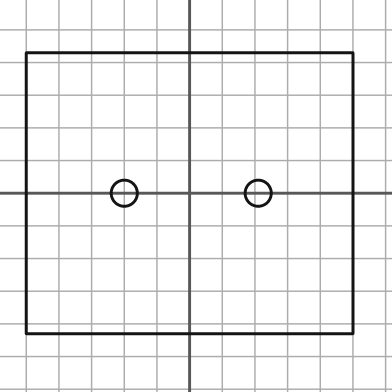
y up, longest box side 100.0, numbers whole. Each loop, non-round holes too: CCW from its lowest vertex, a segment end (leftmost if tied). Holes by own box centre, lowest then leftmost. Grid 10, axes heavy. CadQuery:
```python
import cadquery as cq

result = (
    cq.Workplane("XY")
    .moveTo(-50.0, -43.0)
    .lineTo(50.0, -43.0)
    .lineTo(50.0, 43.0)
    .lineTo(-50.0, 43.0)
    .close()
    .moveTo(-20.0, 0.0)
    .circle(4.0)
    .moveTo(21.0, 0.0)
    .circle(4.0)
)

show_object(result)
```